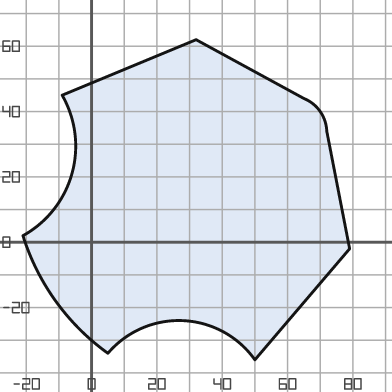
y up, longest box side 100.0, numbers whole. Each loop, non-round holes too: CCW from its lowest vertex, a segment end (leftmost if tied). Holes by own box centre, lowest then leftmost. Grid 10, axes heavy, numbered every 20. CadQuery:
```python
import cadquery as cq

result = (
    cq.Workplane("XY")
    .moveTo(50.0, -36.0)
    .lineTo(79.0, -2.0)
    .lineTo(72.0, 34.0)
    .threePointArc((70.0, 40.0), (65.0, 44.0))
    .lineTo(32.0, 62.0)
    .lineTo(-9.0, 45.0)
    .threePointArc((-6.0, 21.0), (-21.0, 2.0))
    .threePointArc((-11.0, -18.0), (5.0, -34.0))
    .threePointArc((28.0, -24.0), (50.0, -36.0))
    .close()
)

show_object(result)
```